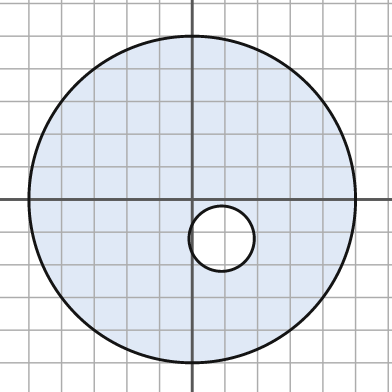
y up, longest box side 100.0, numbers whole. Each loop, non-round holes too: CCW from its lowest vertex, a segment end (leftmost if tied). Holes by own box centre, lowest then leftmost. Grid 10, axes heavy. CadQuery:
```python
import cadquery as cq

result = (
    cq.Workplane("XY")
    .moveTo(0.0, 0.0)
    .circle(50.0)
    .moveTo(9.0, -12.0)
    .circle(10.0)
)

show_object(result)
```